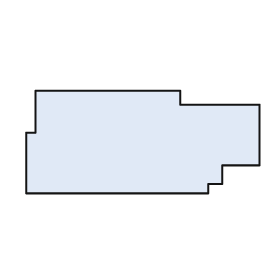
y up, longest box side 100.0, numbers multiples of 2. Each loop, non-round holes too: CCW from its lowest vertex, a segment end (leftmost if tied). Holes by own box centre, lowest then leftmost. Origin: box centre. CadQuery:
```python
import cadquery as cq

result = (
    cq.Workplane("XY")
    .moveTo(-50.0, -22.0)
    .lineTo(28.0, -22.0)
    .lineTo(28.0, -18.0)
    .lineTo(34.0, -18.0)
    .lineTo(34.0, -10.0)
    .lineTo(50.0, -10.0)
    .lineTo(50.0, 16.0)
    .lineTo(16.0, 16.0)
    .lineTo(16.0, 22.0)
    .lineTo(-46.0, 22.0)
    .lineTo(-46.0, 4.0)
    .lineTo(-50.0, 4.0)
    .close()
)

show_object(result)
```